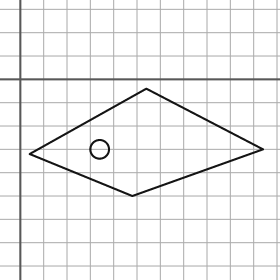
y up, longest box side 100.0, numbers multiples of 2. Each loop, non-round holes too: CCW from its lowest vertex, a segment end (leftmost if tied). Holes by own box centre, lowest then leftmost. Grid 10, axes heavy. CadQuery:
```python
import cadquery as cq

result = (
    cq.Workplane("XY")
    .moveTo(48.0, -50.0)
    .lineTo(104.0, -30.0)
    .lineTo(54.0, -4.0)
    .lineTo(4.0, -32.0)
    .close()
    .moveTo(34.0, -30.0)
    .circle(4.0)
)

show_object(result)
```